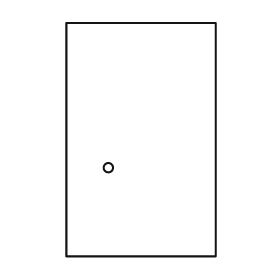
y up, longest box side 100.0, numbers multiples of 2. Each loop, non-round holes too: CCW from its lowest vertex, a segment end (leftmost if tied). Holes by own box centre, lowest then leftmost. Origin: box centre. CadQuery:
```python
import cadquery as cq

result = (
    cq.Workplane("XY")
    .moveTo(-32.0, -50.0)
    .lineTo(32.0, -50.0)
    .lineTo(32.0, 50.0)
    .lineTo(-32.0, 50.0)
    .close()
    .moveTo(-14.0, -12.0)
    .circle(2.0)
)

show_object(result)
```